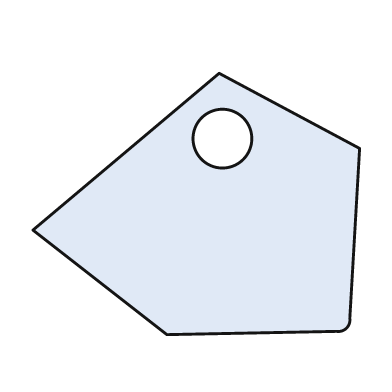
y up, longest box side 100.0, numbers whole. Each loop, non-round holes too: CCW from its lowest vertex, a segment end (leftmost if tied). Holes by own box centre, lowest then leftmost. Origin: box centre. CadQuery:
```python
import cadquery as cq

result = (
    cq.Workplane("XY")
    .moveTo(-9.0, -40.0)
    .lineTo(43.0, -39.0)
    .threePointArc((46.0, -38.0), (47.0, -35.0))
    .lineTo(50.0, 17.0)
    .lineTo(7.0, 40.0)
    .lineTo(-50.0, -8.0)
    .close()
    .moveTo(8.0, 20.0)
    .circle(9.0)
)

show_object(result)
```